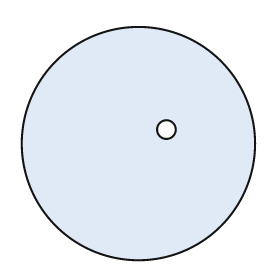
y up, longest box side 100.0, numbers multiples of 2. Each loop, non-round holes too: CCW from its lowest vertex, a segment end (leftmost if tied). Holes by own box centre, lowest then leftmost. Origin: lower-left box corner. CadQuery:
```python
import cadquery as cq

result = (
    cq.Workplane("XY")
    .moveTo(50.0, 50.0)
    .circle(50.0)
    .moveTo(62.0, 56.0)
    .circle(4.0)
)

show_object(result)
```